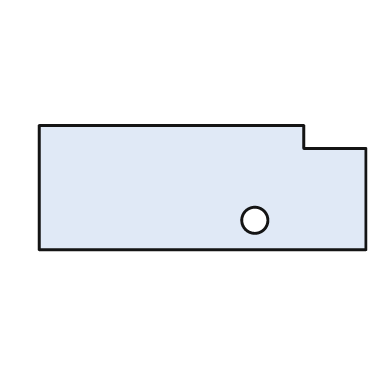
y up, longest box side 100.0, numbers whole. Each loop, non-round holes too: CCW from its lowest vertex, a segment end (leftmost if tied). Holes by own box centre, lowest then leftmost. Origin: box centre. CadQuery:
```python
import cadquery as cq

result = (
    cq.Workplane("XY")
    .moveTo(-50.0, -19.0)
    .lineTo(50.0, -19.0)
    .lineTo(50.0, 12.0)
    .lineTo(31.0, 12.0)
    .lineTo(31.0, 19.0)
    .lineTo(-50.0, 19.0)
    .close()
    .moveTo(16.0, -10.0)
    .circle(4.0)
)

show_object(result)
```